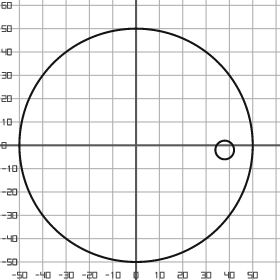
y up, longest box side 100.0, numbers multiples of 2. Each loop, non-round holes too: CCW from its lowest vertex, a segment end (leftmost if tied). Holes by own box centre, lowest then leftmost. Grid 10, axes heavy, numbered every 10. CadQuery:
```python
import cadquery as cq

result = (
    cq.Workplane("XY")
    .moveTo(0.0, 0.0)
    .circle(50.0)
    .moveTo(38.0, -2.0)
    .circle(4.0)
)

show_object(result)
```